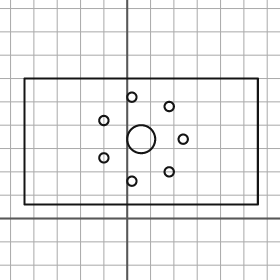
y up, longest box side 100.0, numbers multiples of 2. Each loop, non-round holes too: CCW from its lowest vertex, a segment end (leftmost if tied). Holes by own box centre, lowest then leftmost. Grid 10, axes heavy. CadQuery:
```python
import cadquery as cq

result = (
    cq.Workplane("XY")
    .moveTo(-44.0, 6.0)
    .lineTo(56.0, 6.0)
    .lineTo(56.0, 60.0)
    .lineTo(-44.0, 60.0)
    .close()
    .moveTo(2.0, 16.0)
    .circle(2.0)
    .moveTo(18.0, 20.0)
    .circle(2.0)
    .moveTo(-10.0, 26.0)
    .circle(2.0)
    .moveTo(6.0, 34.0)
    .circle(6.0)
    .moveTo(24.0, 34.0)
    .circle(2.0)
    .moveTo(-10.0, 42.0)
    .circle(2.0)
    .moveTo(18.0, 48.0)
    .circle(2.0)
    .moveTo(2.0, 52.0)
    .circle(2.0)
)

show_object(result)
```